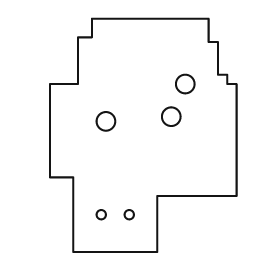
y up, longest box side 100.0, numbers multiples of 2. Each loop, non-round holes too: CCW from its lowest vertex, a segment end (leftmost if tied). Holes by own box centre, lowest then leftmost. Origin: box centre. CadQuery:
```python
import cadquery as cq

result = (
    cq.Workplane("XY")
    .moveTo(-30.0, -50.0)
    .lineTo(6.0, -50.0)
    .lineTo(6.0, -26.0)
    .lineTo(40.0, -26.0)
    .lineTo(40.0, 22.0)
    .lineTo(36.0, 22.0)
    .lineTo(36.0, 26.0)
    .lineTo(32.0, 26.0)
    .lineTo(32.0, 40.0)
    .lineTo(28.0, 40.0)
    .lineTo(28.0, 50.0)
    .lineTo(-22.0, 50.0)
    .lineTo(-22.0, 42.0)
    .lineTo(-28.0, 42.0)
    .lineTo(-28.0, 22.0)
    .lineTo(-40.0, 22.0)
    .lineTo(-40.0, -18.0)
    .lineTo(-30.0, -18.0)
    .close()
    .moveTo(-18.0, -34.0)
    .circle(2.0)
    .moveTo(-6.0, -34.0)
    .circle(2.0)
    .moveTo(-16.0, 6.0)
    .circle(4.0)
    .moveTo(12.0, 8.0)
    .circle(4.0)
    .moveTo(18.0, 22.0)
    .circle(4.0)
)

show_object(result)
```